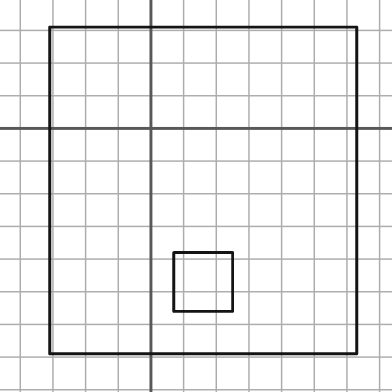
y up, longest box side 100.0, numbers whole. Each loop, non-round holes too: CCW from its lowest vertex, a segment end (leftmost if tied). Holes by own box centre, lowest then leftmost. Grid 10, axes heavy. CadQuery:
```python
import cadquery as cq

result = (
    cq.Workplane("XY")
    .moveTo(-31.0, -69.0)
    .lineTo(63.0, -69.0)
    .lineTo(63.0, 31.0)
    .lineTo(-31.0, 31.0)
    .close()
    .moveTo(7.0, -56.0)
    .lineTo(25.0, -56.0)
    .lineTo(25.0, -38.0)
    .lineTo(7.0, -38.0)
    .close()
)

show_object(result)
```